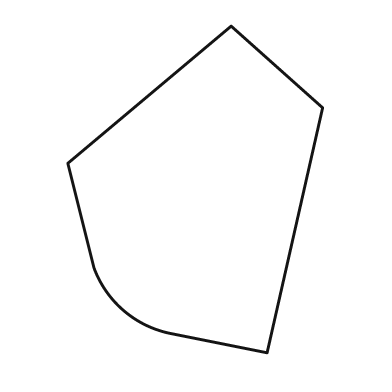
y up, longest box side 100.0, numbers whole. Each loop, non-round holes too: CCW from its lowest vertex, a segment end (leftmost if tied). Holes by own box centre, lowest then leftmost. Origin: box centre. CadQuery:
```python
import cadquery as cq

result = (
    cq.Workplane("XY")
    .moveTo(22.0, -50.0)
    .lineTo(39.0, 25.0)
    .lineTo(11.0, 50.0)
    .lineTo(-39.0, 8.0)
    .lineTo(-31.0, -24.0)
    .threePointArc((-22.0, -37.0), (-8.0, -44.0))
    .close()
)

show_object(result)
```